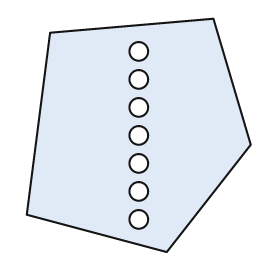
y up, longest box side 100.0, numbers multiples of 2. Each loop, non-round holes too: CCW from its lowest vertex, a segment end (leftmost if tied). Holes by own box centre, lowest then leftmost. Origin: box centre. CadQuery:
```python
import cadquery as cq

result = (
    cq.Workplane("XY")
    .moveTo(12.0, -50.0)
    .lineTo(48.0, -4.0)
    .lineTo(32.0, 50.0)
    .lineTo(-38.0, 44.0)
    .lineTo(-48.0, -34.0)
    .close()
    .moveTo(0.0, -36.0)
    .circle(4.0)
    .moveTo(0.0, -24.0)
    .circle(4.0)
    .moveTo(0.0, -12.0)
    .circle(4.0)
    .moveTo(0.0, 0.0)
    .circle(4.0)
    .moveTo(0.0, 12.0)
    .circle(4.0)
    .moveTo(0.0, 24.0)
    .circle(4.0)
    .moveTo(0.0, 36.0)
    .circle(4.0)
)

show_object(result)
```